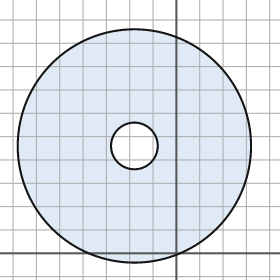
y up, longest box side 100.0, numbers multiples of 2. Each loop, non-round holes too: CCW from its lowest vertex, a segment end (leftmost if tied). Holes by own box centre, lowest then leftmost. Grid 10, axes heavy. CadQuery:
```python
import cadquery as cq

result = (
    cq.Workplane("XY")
    .moveTo(-18.0, 46.0)
    .circle(50.0)
    .moveTo(-18.0, 46.0)
    .circle(10.0)
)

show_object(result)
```